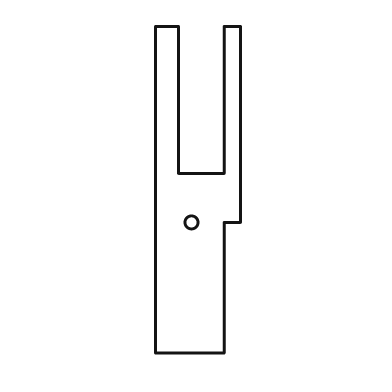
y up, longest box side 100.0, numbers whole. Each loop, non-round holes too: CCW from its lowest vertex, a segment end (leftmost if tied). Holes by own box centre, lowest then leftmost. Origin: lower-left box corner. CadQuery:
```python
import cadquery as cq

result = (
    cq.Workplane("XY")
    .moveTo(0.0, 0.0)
    .lineTo(21.0, 0.0)
    .lineTo(21.0, 40.0)
    .lineTo(26.0, 40.0)
    .lineTo(26.0, 100.0)
    .lineTo(21.0, 100.0)
    .lineTo(21.0, 55.0)
    .lineTo(7.0, 55.0)
    .lineTo(7.0, 100.0)
    .lineTo(0.0, 100.0)
    .close()
    .moveTo(11.0, 40.0)
    .circle(2.0)
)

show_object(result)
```